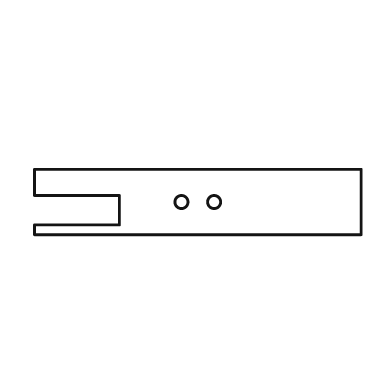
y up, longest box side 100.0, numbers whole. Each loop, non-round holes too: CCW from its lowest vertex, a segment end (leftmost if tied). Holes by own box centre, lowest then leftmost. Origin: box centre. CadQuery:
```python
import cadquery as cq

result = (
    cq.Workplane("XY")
    .moveTo(-50.0, -10.0)
    .lineTo(50.0, -10.0)
    .lineTo(50.0, 10.0)
    .lineTo(-50.0, 10.0)
    .lineTo(-50.0, 2.0)
    .lineTo(-24.0, 2.0)
    .lineTo(-24.0, -7.0)
    .lineTo(-50.0, -7.0)
    .close()
    .moveTo(-5.0, 0.0)
    .circle(2.0)
    .moveTo(5.0, 0.0)
    .circle(2.0)
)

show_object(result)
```